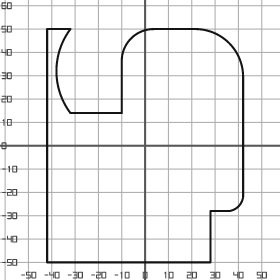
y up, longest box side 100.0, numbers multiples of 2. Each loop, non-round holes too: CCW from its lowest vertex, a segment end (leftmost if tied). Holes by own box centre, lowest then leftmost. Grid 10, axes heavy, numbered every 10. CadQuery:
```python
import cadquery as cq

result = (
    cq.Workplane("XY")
    .moveTo(-42.0, -50.0)
    .lineTo(28.0, -50.0)
    .lineTo(28.0, -28.0)
    .lineTo(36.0, -28.0)
    .threePointArc((40.0, -26.0), (42.0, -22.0))
    .lineTo(42.0, 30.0)
    .threePointArc((36.0, 44.0), (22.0, 50.0))
    .lineTo(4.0, 50.0)
    .threePointArc((-6.0, 46.0), (-10.0, 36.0))
    .lineTo(-10.0, 14.0)
    .lineTo(-32.0, 14.0)
    .threePointArc((-38.0, 32.0), (-32.0, 50.0))
    .lineTo(-42.0, 50.0)
    .close()
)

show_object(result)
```